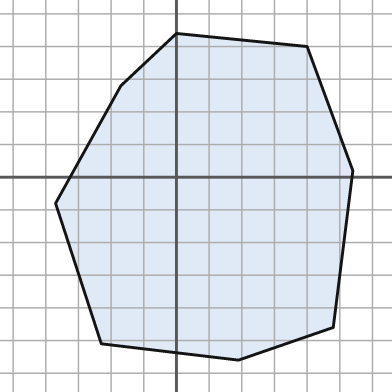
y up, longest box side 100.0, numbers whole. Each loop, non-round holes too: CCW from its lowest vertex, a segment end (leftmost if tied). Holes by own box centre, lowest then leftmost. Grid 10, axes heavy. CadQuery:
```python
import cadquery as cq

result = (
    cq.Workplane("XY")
    .moveTo(19.0, -56.0)
    .lineTo(48.0, -46.0)
    .lineTo(54.0, 2.0)
    .lineTo(40.0, 40.0)
    .lineTo(0.0, 44.0)
    .lineTo(-17.0, 28.0)
    .lineTo(-37.0, -8.0)
    .lineTo(-23.0, -51.0)
    .close()
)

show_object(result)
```